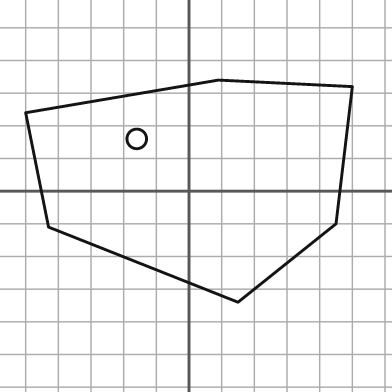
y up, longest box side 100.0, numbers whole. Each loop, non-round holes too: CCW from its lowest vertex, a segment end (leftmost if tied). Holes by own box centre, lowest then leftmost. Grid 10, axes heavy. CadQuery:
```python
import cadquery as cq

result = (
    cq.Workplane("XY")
    .moveTo(15.0, -34.0)
    .lineTo(45.0, -10.0)
    .lineTo(50.0, 32.0)
    .lineTo(9.0, 34.0)
    .lineTo(-50.0, 24.0)
    .lineTo(-43.0, -11.0)
    .close()
    .moveTo(-16.0, 16.0)
    .circle(3.0)
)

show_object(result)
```